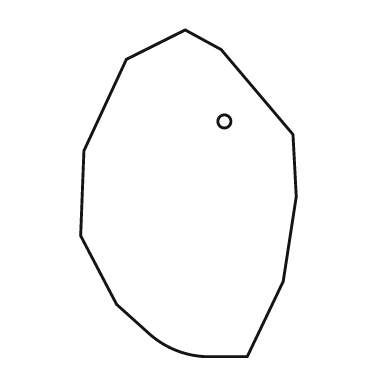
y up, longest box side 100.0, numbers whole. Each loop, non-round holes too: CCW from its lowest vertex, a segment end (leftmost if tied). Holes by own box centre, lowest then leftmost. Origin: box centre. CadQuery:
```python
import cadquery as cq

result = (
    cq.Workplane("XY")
    .moveTo(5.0, -50.0)
    .lineTo(18.0, -50.0)
    .lineTo(29.0, -27.0)
    .lineTo(33.0, -1.0)
    .lineTo(32.0, 18.0)
    .lineTo(10.0, 44.0)
    .lineTo(-1.0, 50.0)
    .lineTo(-19.0, 41.0)
    .lineTo(-32.0, 13.0)
    .lineTo(-33.0, -13.0)
    .lineTo(-22.0, -34.0)
    .lineTo(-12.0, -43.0)
    .threePointArc((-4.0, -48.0), (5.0, -50.0))
    .close()
    .moveTo(11.0, 22.0)
    .circle(2.0)
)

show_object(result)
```